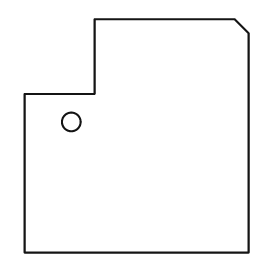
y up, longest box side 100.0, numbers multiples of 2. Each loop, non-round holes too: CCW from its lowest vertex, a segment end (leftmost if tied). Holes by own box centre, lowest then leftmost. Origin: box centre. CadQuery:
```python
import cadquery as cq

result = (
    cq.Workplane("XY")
    .moveTo(-48.0, -50.0)
    .lineTo(48.0, -50.0)
    .lineTo(48.0, 44.0)
    .lineTo(42.0, 50.0)
    .lineTo(-18.0, 50.0)
    .lineTo(-18.0, 18.0)
    .lineTo(-48.0, 18.0)
    .close()
    .moveTo(-28.0, 6.0)
    .circle(4.0)
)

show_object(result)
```